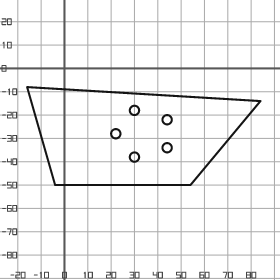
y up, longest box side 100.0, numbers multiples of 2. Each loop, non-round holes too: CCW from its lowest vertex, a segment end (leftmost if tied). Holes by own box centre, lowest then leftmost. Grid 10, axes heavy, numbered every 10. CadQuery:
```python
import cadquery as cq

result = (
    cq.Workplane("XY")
    .moveTo(-4.0, -50.0)
    .lineTo(54.0, -50.0)
    .lineTo(84.0, -14.0)
    .lineTo(-16.0, -8.0)
    .close()
    .moveTo(30.0, -38.0)
    .circle(2.0)
    .moveTo(44.0, -34.0)
    .circle(2.0)
    .moveTo(22.0, -28.0)
    .circle(2.0)
    .moveTo(44.0, -22.0)
    .circle(2.0)
    .moveTo(30.0, -18.0)
    .circle(2.0)
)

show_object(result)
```